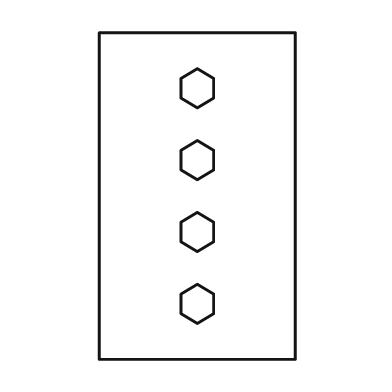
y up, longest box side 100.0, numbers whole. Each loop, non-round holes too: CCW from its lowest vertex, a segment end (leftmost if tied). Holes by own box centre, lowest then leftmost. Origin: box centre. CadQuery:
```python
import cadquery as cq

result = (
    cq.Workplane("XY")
    .moveTo(-30.0, -50.0)
    .lineTo(30.0, -50.0)
    .lineTo(30.0, 50.0)
    .lineTo(-30.0, 50.0)
    .close()
    .moveTo(0.0, -39.0)
    .lineTo(5.0, -36.0)
    .lineTo(5.0, -30.0)
    .lineTo(0.0, -27.0)
    .lineTo(-5.0, -30.0)
    .lineTo(-5.0, -36.0)
    .close()
    .moveTo(0.0, -17.0)
    .lineTo(5.0, -14.0)
    .lineTo(5.0, -8.0)
    .lineTo(0.0, -5.0)
    .lineTo(-5.0, -8.0)
    .lineTo(-5.0, -14.0)
    .close()
    .moveTo(0.0, 5.0)
    .lineTo(5.0, 8.0)
    .lineTo(5.0, 14.0)
    .lineTo(0.0, 17.0)
    .lineTo(-5.0, 14.0)
    .lineTo(-5.0, 8.0)
    .close()
    .moveTo(0.0, 27.0)
    .lineTo(5.0, 30.0)
    .lineTo(5.0, 36.0)
    .lineTo(0.0, 39.0)
    .lineTo(-5.0, 36.0)
    .lineTo(-5.0, 30.0)
    .close()
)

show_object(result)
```